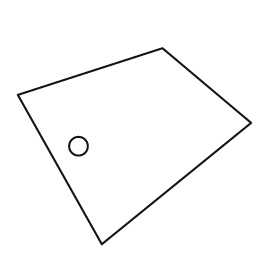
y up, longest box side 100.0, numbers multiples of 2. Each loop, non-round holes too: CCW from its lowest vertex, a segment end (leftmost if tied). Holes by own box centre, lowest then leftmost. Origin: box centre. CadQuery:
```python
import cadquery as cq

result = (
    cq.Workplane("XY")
    .moveTo(-14.0, -42.0)
    .lineTo(50.0, 10.0)
    .lineTo(12.0, 42.0)
    .lineTo(-50.0, 22.0)
    .close()
    .moveTo(-24.0, 0.0)
    .circle(4.0)
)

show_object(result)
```